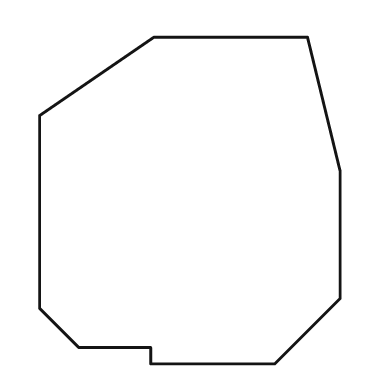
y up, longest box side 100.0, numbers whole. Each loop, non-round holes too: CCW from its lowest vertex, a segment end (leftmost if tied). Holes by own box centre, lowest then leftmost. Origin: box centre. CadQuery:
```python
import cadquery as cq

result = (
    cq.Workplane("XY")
    .moveTo(-12.0, -50.0)
    .lineTo(26.0, -50.0)
    .lineTo(46.0, -30.0)
    .lineTo(46.0, 9.0)
    .lineTo(36.0, 50.0)
    .lineTo(-11.0, 50.0)
    .lineTo(-46.0, 26.0)
    .lineTo(-46.0, -33.0)
    .lineTo(-34.0, -45.0)
    .lineTo(-12.0, -45.0)
    .close()
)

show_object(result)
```